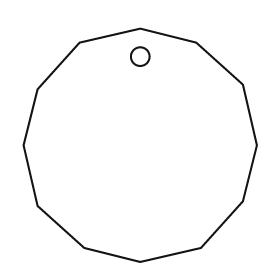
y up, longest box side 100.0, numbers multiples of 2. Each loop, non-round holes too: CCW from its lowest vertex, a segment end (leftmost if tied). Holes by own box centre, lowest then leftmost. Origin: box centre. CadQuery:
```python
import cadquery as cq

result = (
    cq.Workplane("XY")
    .moveTo(0.0, -50.0)
    .lineTo(26.0, -44.0)
    .lineTo(44.0, -24.0)
    .lineTo(50.0, 0.0)
    .lineTo(44.0, 26.0)
    .lineTo(24.0, 44.0)
    .lineTo(0.0, 50.0)
    .lineTo(-26.0, 44.0)
    .lineTo(-44.0, 24.0)
    .lineTo(-50.0, 0.0)
    .lineTo(-44.0, -26.0)
    .lineTo(-24.0, -44.0)
    .close()
    .moveTo(0.0, 38.0)
    .circle(4.0)
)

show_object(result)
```